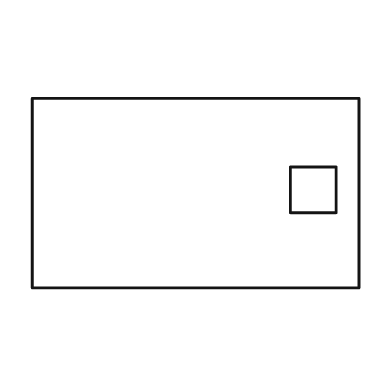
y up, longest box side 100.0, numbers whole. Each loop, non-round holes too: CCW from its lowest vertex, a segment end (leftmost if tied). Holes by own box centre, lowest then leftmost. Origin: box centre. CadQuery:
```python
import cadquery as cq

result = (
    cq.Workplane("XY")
    .moveTo(-50.0, -29.0)
    .lineTo(50.0, -29.0)
    .lineTo(50.0, 29.0)
    .lineTo(-50.0, 29.0)
    .close()
    .moveTo(29.0, -6.0)
    .lineTo(43.0, -6.0)
    .lineTo(43.0, 8.0)
    .lineTo(29.0, 8.0)
    .close()
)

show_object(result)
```